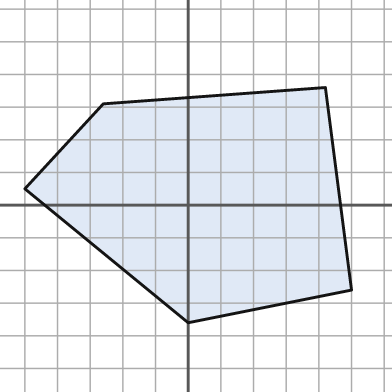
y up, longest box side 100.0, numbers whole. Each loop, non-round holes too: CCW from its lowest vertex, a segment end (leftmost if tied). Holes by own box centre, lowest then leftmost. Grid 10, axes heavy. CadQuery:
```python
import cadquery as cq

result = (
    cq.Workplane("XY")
    .moveTo(0.0, -36.0)
    .lineTo(50.0, -26.0)
    .lineTo(42.0, 36.0)
    .lineTo(-26.0, 31.0)
    .lineTo(-50.0, 5.0)
    .close()
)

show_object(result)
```